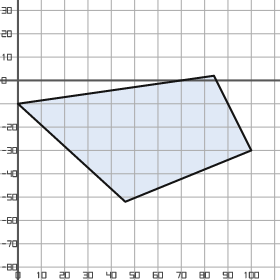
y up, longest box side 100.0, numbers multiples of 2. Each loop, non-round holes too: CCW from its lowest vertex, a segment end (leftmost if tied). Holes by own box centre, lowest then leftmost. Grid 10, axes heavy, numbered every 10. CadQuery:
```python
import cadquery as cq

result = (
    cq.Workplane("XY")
    .moveTo(46.0, -52.0)
    .lineTo(100.0, -30.0)
    .lineTo(84.0, 2.0)
    .lineTo(0.0, -10.0)
    .close()
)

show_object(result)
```